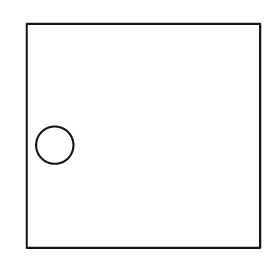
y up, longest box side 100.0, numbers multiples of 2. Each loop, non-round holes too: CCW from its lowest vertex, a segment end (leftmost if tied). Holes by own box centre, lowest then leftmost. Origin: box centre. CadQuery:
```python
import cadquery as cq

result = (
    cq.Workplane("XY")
    .moveTo(-50.0, -48.0)
    .lineTo(50.0, -48.0)
    .lineTo(50.0, 48.0)
    .lineTo(-50.0, 48.0)
    .close()
    .moveTo(-38.0, -4.0)
    .circle(8.0)
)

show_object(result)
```